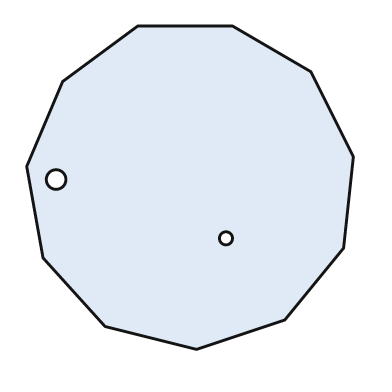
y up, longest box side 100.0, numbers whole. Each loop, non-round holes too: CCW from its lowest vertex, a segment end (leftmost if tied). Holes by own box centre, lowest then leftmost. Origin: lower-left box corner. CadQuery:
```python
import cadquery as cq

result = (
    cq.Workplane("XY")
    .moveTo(52.0, 0.0)
    .lineTo(79.0, 9.0)
    .lineTo(97.0, 31.0)
    .lineTo(100.0, 59.0)
    .lineTo(87.0, 85.0)
    .lineTo(63.0, 99.0)
    .lineTo(34.0, 99.0)
    .lineTo(11.0, 82.0)
    .lineTo(0.0, 56.0)
    .lineTo(5.0, 28.0)
    .lineTo(24.0, 7.0)
    .close()
    .moveTo(61.0, 34.0)
    .circle(2.0)
    .moveTo(9.0, 52.0)
    .circle(3.0)
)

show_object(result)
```